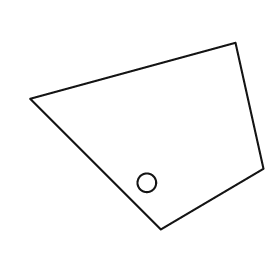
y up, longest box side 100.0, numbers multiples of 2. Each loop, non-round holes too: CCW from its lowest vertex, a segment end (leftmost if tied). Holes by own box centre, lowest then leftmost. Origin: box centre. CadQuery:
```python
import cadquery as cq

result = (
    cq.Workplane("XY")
    .moveTo(6.0, -40.0)
    .lineTo(50.0, -14.0)
    .lineTo(38.0, 40.0)
    .lineTo(-50.0, 16.0)
    .close()
    .moveTo(0.0, -20.0)
    .circle(4.0)
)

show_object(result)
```